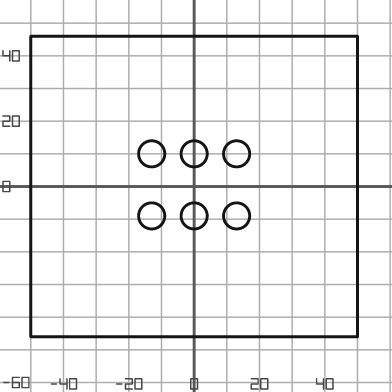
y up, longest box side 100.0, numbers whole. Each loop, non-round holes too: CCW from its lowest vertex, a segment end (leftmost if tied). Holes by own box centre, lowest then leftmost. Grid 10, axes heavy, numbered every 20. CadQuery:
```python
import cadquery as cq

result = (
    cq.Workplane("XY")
    .moveTo(-50.0, -46.0)
    .lineTo(50.0, -46.0)
    .lineTo(50.0, 46.0)
    .lineTo(-50.0, 46.0)
    .close()
    .moveTo(-13.0, -9.0)
    .circle(4.0)
    .moveTo(0.0, -9.0)
    .circle(4.0)
    .moveTo(13.0, -9.0)
    .circle(4.0)
    .moveTo(-13.0, 10.0)
    .circle(4.0)
    .moveTo(0.0, 10.0)
    .circle(4.0)
    .moveTo(13.0, 10.0)
    .circle(4.0)
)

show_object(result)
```